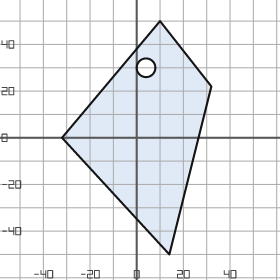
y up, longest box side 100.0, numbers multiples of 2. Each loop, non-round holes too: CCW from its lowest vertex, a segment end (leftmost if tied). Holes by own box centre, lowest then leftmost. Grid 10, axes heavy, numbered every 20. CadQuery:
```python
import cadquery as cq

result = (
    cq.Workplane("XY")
    .moveTo(14.0, -50.0)
    .lineTo(32.0, 22.0)
    .lineTo(10.0, 50.0)
    .lineTo(-32.0, 0.0)
    .close()
    .moveTo(4.0, 30.0)
    .circle(4.0)
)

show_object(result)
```